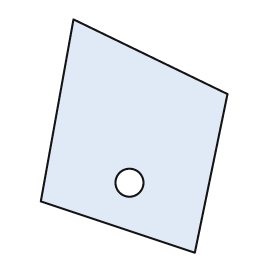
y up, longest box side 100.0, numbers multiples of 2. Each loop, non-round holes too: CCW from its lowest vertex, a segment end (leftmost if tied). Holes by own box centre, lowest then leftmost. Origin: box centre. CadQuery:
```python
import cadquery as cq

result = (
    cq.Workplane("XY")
    .moveTo(26.0, -50.0)
    .lineTo(40.0, 18.0)
    .lineTo(-26.0, 50.0)
    .lineTo(-40.0, -28.0)
    .close()
    .moveTo(-2.0, -20.0)
    .circle(6.0)
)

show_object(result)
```